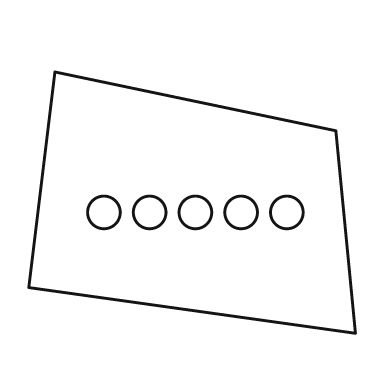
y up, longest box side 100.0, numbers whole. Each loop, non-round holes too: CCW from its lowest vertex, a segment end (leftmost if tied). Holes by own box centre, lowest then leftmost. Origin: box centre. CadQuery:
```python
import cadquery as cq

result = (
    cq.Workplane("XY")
    .moveTo(50.0, -40.0)
    .lineTo(44.0, 22.0)
    .lineTo(-42.0, 40.0)
    .lineTo(-50.0, -26.0)
    .close()
    .moveTo(-27.0, -3.0)
    .circle(5.0)
    .moveTo(-13.0, -3.0)
    .circle(5.0)
    .moveTo(1.0, -3.0)
    .circle(5.0)
    .moveTo(15.0, -3.0)
    .circle(5.0)
    .moveTo(29.0, -3.0)
    .circle(5.0)
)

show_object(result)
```